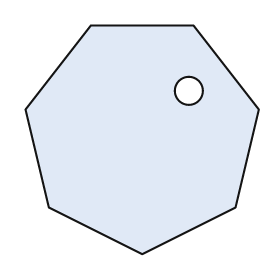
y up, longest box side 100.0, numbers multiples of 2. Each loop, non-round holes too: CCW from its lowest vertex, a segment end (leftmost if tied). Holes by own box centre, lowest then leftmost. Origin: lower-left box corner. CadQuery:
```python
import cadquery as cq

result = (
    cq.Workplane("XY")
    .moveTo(50.0, 0.0)
    .lineTo(90.0, 20.0)
    .lineTo(100.0, 62.0)
    .lineTo(72.0, 98.0)
    .lineTo(28.0, 98.0)
    .lineTo(0.0, 62.0)
    .lineTo(10.0, 20.0)
    .close()
    .moveTo(70.0, 70.0)
    .circle(6.0)
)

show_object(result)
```